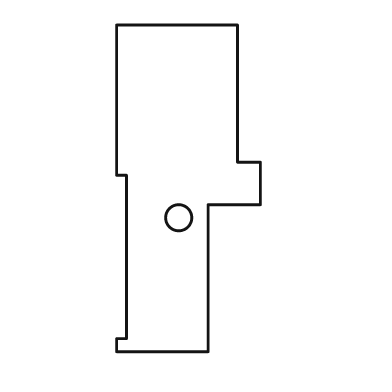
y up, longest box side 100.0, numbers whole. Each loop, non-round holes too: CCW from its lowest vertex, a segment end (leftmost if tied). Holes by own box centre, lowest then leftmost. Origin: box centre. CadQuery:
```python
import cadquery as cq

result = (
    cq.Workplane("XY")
    .moveTo(-22.0, -50.0)
    .lineTo(6.0, -50.0)
    .lineTo(6.0, -5.0)
    .lineTo(22.0, -5.0)
    .lineTo(22.0, 8.0)
    .lineTo(15.0, 8.0)
    .lineTo(15.0, 50.0)
    .lineTo(-22.0, 50.0)
    .lineTo(-22.0, 4.0)
    .lineTo(-19.0, 4.0)
    .lineTo(-19.0, -46.0)
    .lineTo(-22.0, -46.0)
    .close()
    .moveTo(-3.0, -9.0)
    .circle(4.0)
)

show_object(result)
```